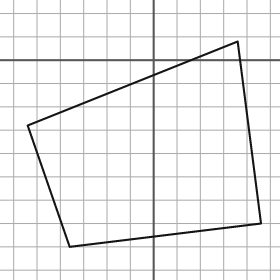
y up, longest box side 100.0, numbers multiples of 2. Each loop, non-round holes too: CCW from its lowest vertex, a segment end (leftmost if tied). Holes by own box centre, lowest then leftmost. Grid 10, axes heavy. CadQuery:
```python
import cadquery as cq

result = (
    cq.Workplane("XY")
    .moveTo(-36.0, -80.0)
    .lineTo(46.0, -70.0)
    .lineTo(36.0, 8.0)
    .lineTo(-54.0, -28.0)
    .close()
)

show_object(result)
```